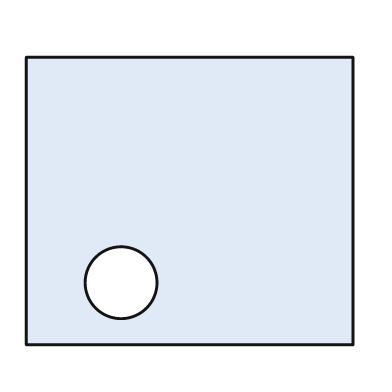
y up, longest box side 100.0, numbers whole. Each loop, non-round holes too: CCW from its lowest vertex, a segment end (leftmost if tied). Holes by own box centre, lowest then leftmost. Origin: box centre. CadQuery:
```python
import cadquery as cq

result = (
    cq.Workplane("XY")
    .moveTo(-50.0, -44.0)
    .lineTo(50.0, -44.0)
    .lineTo(50.0, 44.0)
    .lineTo(-50.0, 44.0)
    .close()
    .moveTo(-21.0, -25.0)
    .circle(11.0)
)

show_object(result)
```